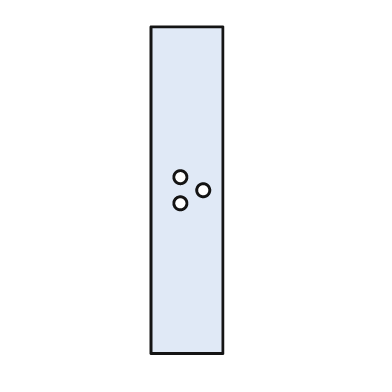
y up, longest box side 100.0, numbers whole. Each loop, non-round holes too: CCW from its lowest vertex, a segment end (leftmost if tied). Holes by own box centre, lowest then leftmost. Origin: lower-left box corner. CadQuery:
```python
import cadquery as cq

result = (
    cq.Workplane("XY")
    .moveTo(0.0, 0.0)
    .lineTo(22.0, 0.0)
    .lineTo(22.0, 100.0)
    .lineTo(0.0, 100.0)
    .close()
    .moveTo(9.0, 46.0)
    .circle(2.0)
    .moveTo(16.0, 50.0)
    .circle(2.0)
    .moveTo(9.0, 54.0)
    .circle(2.0)
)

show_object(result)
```